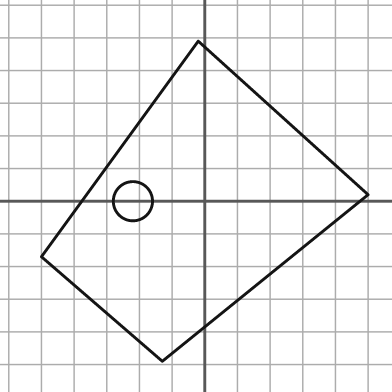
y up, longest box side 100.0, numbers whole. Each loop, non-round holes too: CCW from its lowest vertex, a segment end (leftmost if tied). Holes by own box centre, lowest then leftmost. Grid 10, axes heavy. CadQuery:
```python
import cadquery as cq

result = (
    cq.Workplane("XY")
    .moveTo(-13.0, -49.0)
    .lineTo(50.0, 2.0)
    .lineTo(-2.0, 49.0)
    .lineTo(-50.0, -17.0)
    .close()
    .moveTo(-22.0, 0.0)
    .circle(6.0)
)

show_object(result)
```